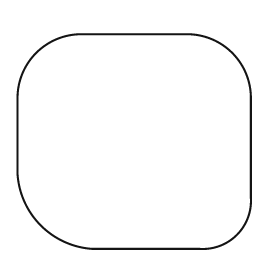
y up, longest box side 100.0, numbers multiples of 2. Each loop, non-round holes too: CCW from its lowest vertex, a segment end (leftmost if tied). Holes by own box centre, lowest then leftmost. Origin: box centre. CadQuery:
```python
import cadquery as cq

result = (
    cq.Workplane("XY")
    .moveTo(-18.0, -46.0)
    .lineTo(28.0, -46.0)
    .threePointArc((44.0, -40.0), (50.0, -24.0))
    .lineTo(50.0, 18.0)
    .threePointArc((42.0, 38.0), (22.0, 46.0))
    .lineTo(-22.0, 46.0)
    .threePointArc((-42.0, 38.0), (-50.0, 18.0))
    .lineTo(-50.0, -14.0)
    .threePointArc((-40.0, -36.0), (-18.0, -46.0))
    .close()
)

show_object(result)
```